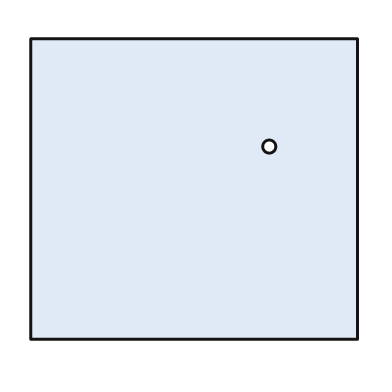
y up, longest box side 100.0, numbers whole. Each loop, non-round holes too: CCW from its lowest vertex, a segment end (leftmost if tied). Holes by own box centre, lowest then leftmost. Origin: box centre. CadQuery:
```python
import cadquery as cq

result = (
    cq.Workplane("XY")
    .moveTo(-50.0, -46.0)
    .lineTo(50.0, -46.0)
    .lineTo(50.0, 46.0)
    .lineTo(-50.0, 46.0)
    .close()
    .moveTo(23.0, 13.0)
    .circle(2.0)
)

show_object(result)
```